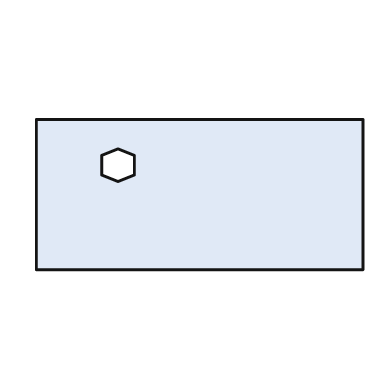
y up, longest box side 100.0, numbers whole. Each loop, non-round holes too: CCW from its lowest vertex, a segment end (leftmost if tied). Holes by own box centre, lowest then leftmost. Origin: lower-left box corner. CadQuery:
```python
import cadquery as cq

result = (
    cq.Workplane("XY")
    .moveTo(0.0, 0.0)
    .lineTo(100.0, 0.0)
    .lineTo(100.0, 46.0)
    .lineTo(0.0, 46.0)
    .close()
    .moveTo(25.0, 27.0)
    .lineTo(30.0, 29.0)
    .lineTo(30.0, 35.0)
    .lineTo(25.0, 37.0)
    .lineTo(20.0, 35.0)
    .lineTo(20.0, 29.0)
    .close()
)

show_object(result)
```